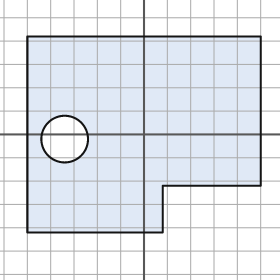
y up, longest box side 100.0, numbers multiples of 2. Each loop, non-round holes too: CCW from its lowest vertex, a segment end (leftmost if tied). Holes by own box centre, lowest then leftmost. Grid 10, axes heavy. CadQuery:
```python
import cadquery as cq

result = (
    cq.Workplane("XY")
    .moveTo(-50.0, -42.0)
    .lineTo(8.0, -42.0)
    .lineTo(8.0, -22.0)
    .lineTo(50.0, -22.0)
    .lineTo(50.0, 42.0)
    .lineTo(-50.0, 42.0)
    .close()
    .moveTo(-34.0, -2.0)
    .circle(10.0)
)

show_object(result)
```